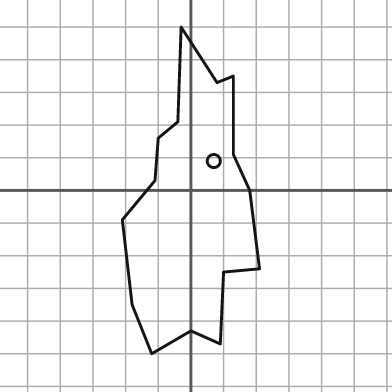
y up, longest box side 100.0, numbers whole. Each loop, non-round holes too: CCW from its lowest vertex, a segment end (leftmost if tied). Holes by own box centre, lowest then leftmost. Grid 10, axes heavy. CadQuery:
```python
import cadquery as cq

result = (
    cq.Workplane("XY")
    .moveTo(-12.0, -50.0)
    .lineTo(0.0, -43.0)
    .lineTo(9.0, -47.0)
    .lineTo(10.0, -25.0)
    .lineTo(21.0, -24.0)
    .lineTo(18.0, 0.0)
    .lineTo(13.0, 11.0)
    .lineTo(13.0, 35.0)
    .lineTo(8.0, 33.0)
    .lineTo(-3.0, 50.0)
    .lineTo(-4.0, 21.0)
    .lineTo(-10.0, 16.0)
    .lineTo(-11.0, 3.0)
    .lineTo(-21.0, -9.0)
    .lineTo(-18.0, -35.0)
    .close()
    .moveTo(7.0, 9.0)
    .circle(2.0)
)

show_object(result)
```